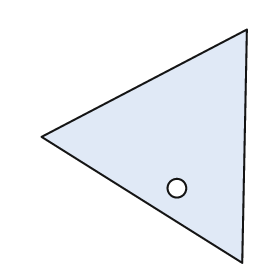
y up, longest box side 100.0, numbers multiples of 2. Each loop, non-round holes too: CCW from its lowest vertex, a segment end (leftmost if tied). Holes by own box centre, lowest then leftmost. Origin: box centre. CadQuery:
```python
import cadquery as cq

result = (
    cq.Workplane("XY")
    .moveTo(42.0, -50.0)
    .lineTo(44.0, 50.0)
    .lineTo(-44.0, 4.0)
    .close()
    .moveTo(14.0, -18.0)
    .circle(4.0)
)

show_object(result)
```